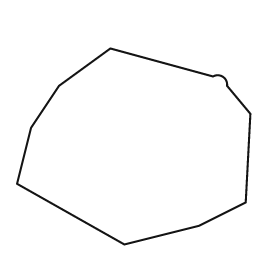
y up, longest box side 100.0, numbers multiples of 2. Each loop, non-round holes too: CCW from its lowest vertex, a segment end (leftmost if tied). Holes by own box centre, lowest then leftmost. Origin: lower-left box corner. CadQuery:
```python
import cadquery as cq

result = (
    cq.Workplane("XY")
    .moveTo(46.0, 0.0)
    .lineTo(78.0, 8.0)
    .lineTo(98.0, 18.0)
    .lineTo(100.0, 56.0)
    .lineTo(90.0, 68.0)
    .threePointArc((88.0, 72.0), (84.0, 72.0))
    .lineTo(40.0, 84.0)
    .lineTo(18.0, 68.0)
    .lineTo(6.0, 50.0)
    .lineTo(0.0, 26.0)
    .close()
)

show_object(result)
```